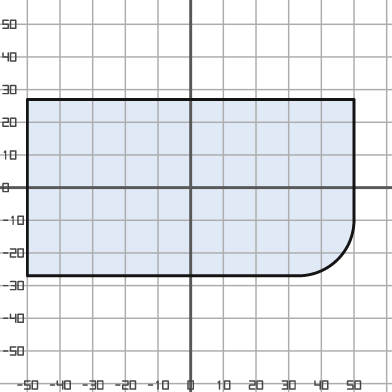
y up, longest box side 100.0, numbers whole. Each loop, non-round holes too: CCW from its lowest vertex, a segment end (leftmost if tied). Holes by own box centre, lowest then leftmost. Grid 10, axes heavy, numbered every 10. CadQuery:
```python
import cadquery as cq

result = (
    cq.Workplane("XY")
    .moveTo(-50.0, -27.0)
    .lineTo(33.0, -27.0)
    .threePointArc((45.0, -22.0), (50.0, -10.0))
    .lineTo(50.0, 27.0)
    .lineTo(-50.0, 27.0)
    .close()
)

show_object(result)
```